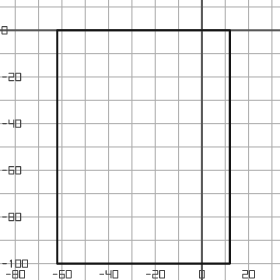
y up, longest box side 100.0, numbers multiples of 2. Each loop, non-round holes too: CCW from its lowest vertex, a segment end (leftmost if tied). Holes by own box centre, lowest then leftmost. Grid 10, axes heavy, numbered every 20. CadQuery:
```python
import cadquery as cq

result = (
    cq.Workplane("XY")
    .moveTo(-62.0, -100.0)
    .lineTo(12.0, -100.0)
    .lineTo(12.0, 0.0)
    .lineTo(-62.0, 0.0)
    .close()
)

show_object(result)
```